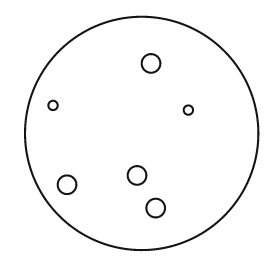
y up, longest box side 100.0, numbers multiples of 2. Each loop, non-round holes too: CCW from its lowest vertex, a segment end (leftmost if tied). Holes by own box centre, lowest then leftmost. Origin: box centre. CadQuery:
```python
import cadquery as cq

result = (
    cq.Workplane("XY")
    .moveTo(0.0, 0.0)
    .circle(50.0)
    .moveTo(6.0, -32.0)
    .circle(4.0)
    .moveTo(-32.0, -22.0)
    .circle(4.0)
    .moveTo(-2.0, -18.0)
    .circle(4.0)
    .moveTo(20.0, 10.0)
    .circle(2.0)
    .moveTo(-38.0, 12.0)
    .circle(2.0)
    .moveTo(4.0, 30.0)
    .circle(4.0)
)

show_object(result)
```